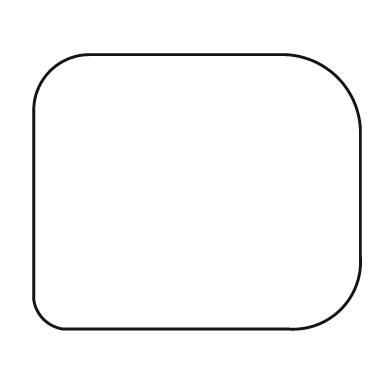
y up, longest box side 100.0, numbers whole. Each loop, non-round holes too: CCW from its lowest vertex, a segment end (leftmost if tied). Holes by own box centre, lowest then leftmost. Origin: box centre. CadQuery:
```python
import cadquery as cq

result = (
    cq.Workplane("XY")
    .moveTo(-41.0, -42.0)
    .lineTo(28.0, -42.0)
    .threePointArc((44.0, -36.0), (50.0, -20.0))
    .lineTo(50.0, 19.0)
    .threePointArc((43.0, 35.0), (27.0, 42.0))
    .lineTo(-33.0, 42.0)
    .threePointArc((-45.0, 37.0), (-50.0, 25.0))
    .lineTo(-50.0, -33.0)
    .threePointArc((-47.0, -39.0), (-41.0, -42.0))
    .close()
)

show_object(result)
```